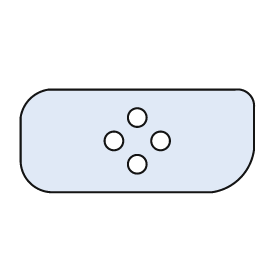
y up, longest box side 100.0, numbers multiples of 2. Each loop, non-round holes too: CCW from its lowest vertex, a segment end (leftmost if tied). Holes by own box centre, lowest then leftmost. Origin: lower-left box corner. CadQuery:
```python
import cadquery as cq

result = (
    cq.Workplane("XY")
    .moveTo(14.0, 0.0)
    .lineTo(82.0, 0.0)
    .threePointArc((94.0, 6.0), (100.0, 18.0))
    .lineTo(100.0, 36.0)
    .threePointArc((98.0, 42.0), (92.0, 44.0))
    .lineTo(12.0, 44.0)
    .threePointArc((4.0, 40.0), (0.0, 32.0))
    .lineTo(0.0, 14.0)
    .threePointArc((4.0, 4.0), (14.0, 0.0))
    .close()
    .moveTo(50.0, 12.0)
    .circle(4.0)
    .moveTo(40.0, 22.0)
    .circle(4.0)
    .moveTo(60.0, 22.0)
    .circle(4.0)
    .moveTo(50.0, 32.0)
    .circle(4.0)
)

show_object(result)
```